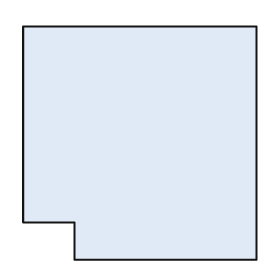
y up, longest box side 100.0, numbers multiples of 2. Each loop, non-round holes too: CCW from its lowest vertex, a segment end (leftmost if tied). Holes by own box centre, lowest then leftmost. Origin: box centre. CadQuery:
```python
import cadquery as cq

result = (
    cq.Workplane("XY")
    .moveTo(-28.0, -50.0)
    .lineTo(50.0, -50.0)
    .lineTo(50.0, 50.0)
    .lineTo(-50.0, 50.0)
    .lineTo(-50.0, -34.0)
    .lineTo(-28.0, -34.0)
    .close()
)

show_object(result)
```